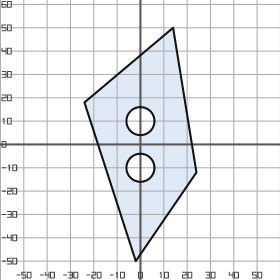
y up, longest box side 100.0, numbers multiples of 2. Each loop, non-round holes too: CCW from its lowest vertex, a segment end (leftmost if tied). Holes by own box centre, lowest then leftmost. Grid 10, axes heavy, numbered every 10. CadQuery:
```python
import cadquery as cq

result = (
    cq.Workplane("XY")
    .moveTo(-2.0, -50.0)
    .lineTo(24.0, -12.0)
    .lineTo(14.0, 50.0)
    .lineTo(-24.0, 18.0)
    .close()
    .moveTo(0.0, -10.0)
    .circle(6.0)
    .moveTo(0.0, 10.0)
    .circle(6.0)
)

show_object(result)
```